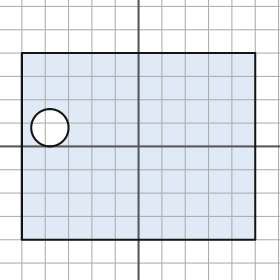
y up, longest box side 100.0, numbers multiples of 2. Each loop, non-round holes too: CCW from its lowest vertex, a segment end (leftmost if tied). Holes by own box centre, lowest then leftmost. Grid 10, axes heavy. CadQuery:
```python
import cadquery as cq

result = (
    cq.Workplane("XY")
    .moveTo(-50.0, -40.0)
    .lineTo(50.0, -40.0)
    .lineTo(50.0, 40.0)
    .lineTo(-50.0, 40.0)
    .close()
    .moveTo(-38.0, 8.0)
    .circle(8.0)
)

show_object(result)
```